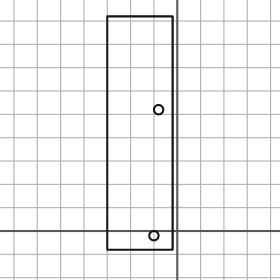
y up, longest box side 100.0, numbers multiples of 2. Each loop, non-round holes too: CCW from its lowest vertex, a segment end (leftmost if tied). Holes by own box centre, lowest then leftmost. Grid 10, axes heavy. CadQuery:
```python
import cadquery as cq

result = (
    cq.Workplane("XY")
    .moveTo(-30.0, -8.0)
    .lineTo(-2.0, -8.0)
    .lineTo(-2.0, 92.0)
    .lineTo(-30.0, 92.0)
    .close()
    .moveTo(-10.0, -2.0)
    .circle(2.0)
    .moveTo(-8.0, 52.0)
    .circle(2.0)
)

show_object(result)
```